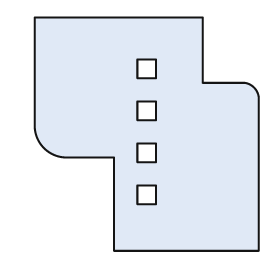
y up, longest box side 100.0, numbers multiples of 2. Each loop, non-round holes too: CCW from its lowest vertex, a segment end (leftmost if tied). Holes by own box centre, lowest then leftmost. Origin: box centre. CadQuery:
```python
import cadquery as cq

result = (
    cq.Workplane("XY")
    .moveTo(-14.0, -50.0)
    .lineTo(48.0, -50.0)
    .lineTo(48.0, 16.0)
    .threePointArc((46.0, 20.0), (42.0, 22.0))
    .lineTo(24.0, 22.0)
    .lineTo(24.0, 50.0)
    .lineTo(-48.0, 50.0)
    .lineTo(-48.0, 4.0)
    .threePointArc((-44.0, -6.0), (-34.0, -10.0))
    .lineTo(-14.0, -10.0)
    .close()
    .moveTo(-4.0, -30.0)
    .lineTo(4.0, -30.0)
    .lineTo(4.0, -22.0)
    .lineTo(-4.0, -22.0)
    .close()
    .moveTo(-4.0, -12.0)
    .lineTo(4.0, -12.0)
    .lineTo(4.0, -4.0)
    .lineTo(-4.0, -4.0)
    .close()
    .moveTo(-4.0, 6.0)
    .lineTo(4.0, 6.0)
    .lineTo(4.0, 14.0)
    .lineTo(-4.0, 14.0)
    .close()
    .moveTo(-4.0, 24.0)
    .lineTo(4.0, 24.0)
    .lineTo(4.0, 32.0)
    .lineTo(-4.0, 32.0)
    .close()
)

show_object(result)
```